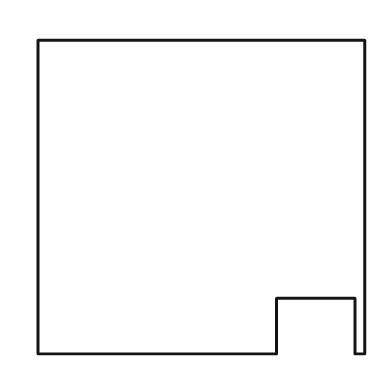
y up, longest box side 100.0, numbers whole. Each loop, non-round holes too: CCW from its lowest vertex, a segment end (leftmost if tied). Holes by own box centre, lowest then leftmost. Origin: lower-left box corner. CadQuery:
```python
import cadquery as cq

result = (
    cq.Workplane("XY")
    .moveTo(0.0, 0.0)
    .lineTo(73.0, 0.0)
    .lineTo(73.0, 17.0)
    .lineTo(97.0, 17.0)
    .lineTo(97.0, 0.0)
    .lineTo(100.0, 0.0)
    .lineTo(100.0, 96.0)
    .lineTo(0.0, 96.0)
    .close()
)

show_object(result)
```